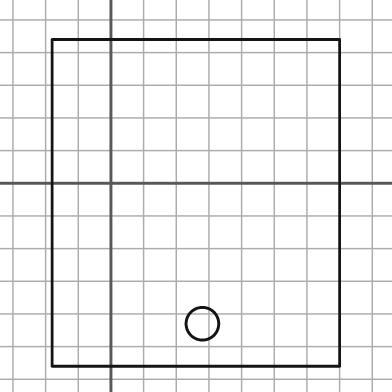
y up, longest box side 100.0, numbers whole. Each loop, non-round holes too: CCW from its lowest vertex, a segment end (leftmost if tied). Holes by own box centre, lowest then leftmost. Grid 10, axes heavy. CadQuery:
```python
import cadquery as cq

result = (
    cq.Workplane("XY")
    .moveTo(-18.0, -56.0)
    .lineTo(70.0, -56.0)
    .lineTo(70.0, 44.0)
    .lineTo(-18.0, 44.0)
    .close()
    .moveTo(28.0, -43.0)
    .circle(5.0)
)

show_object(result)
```